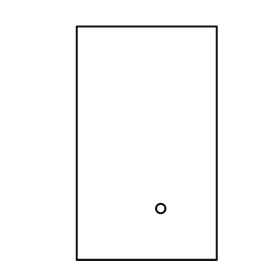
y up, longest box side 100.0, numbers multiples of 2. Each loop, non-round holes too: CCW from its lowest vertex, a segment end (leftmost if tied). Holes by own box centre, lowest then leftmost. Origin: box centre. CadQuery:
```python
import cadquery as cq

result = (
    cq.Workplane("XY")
    .moveTo(-30.0, -50.0)
    .lineTo(30.0, -50.0)
    .lineTo(30.0, 50.0)
    .lineTo(-30.0, 50.0)
    .close()
    .moveTo(6.0, -28.0)
    .circle(2.0)
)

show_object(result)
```